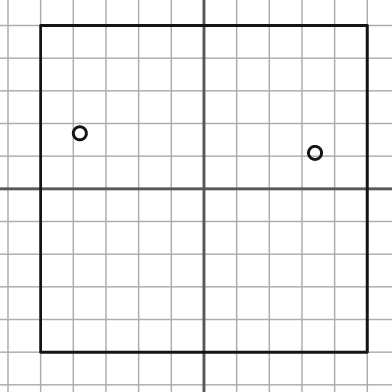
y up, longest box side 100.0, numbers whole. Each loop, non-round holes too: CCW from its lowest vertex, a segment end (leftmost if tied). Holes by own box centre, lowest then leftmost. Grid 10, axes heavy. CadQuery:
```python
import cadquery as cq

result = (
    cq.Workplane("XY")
    .moveTo(-50.0, -50.0)
    .lineTo(50.0, -50.0)
    .lineTo(50.0, 50.0)
    .lineTo(-50.0, 50.0)
    .close()
    .moveTo(34.0, 11.0)
    .circle(2.0)
    .moveTo(-38.0, 17.0)
    .circle(2.0)
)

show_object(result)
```